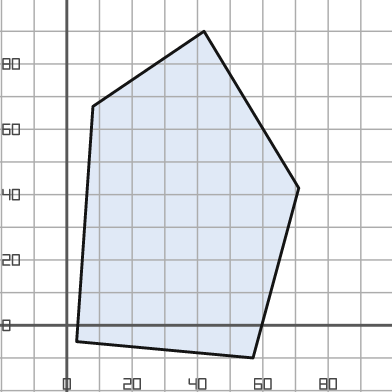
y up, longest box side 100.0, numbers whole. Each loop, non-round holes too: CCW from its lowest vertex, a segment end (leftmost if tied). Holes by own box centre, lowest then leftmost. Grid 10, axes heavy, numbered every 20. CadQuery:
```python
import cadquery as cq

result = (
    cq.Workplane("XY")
    .moveTo(57.0, -10.0)
    .lineTo(71.0, 42.0)
    .lineTo(42.0, 90.0)
    .lineTo(8.0, 67.0)
    .lineTo(3.0, -5.0)
    .close()
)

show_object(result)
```